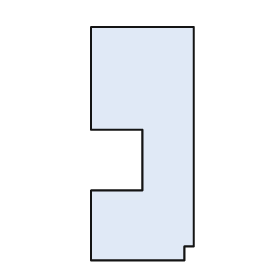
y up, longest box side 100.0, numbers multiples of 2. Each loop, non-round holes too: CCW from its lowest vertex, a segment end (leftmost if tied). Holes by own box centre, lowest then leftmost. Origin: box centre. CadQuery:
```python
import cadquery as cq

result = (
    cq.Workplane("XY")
    .moveTo(-22.0, -50.0)
    .lineTo(18.0, -50.0)
    .lineTo(18.0, -44.0)
    .lineTo(22.0, -44.0)
    .lineTo(22.0, 50.0)
    .lineTo(-22.0, 50.0)
    .lineTo(-22.0, 6.0)
    .lineTo(0.0, 6.0)
    .lineTo(0.0, -20.0)
    .lineTo(-22.0, -20.0)
    .close()
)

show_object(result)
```